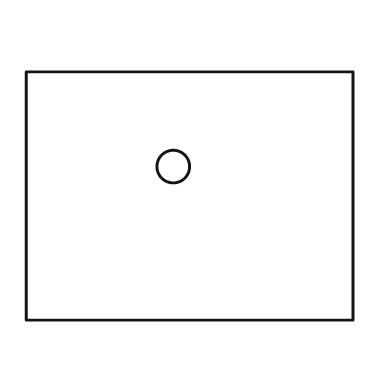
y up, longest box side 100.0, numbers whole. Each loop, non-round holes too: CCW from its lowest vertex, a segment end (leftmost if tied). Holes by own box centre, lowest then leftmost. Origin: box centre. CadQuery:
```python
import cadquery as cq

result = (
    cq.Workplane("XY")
    .moveTo(-50.0, -38.0)
    .lineTo(50.0, -38.0)
    .lineTo(50.0, 38.0)
    .lineTo(-50.0, 38.0)
    .close()
    .moveTo(-5.0, 9.0)
    .circle(5.0)
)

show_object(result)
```